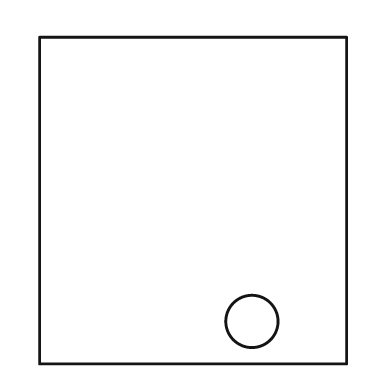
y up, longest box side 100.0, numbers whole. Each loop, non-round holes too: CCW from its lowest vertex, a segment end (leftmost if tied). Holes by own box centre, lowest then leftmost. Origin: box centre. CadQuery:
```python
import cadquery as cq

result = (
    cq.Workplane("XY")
    .moveTo(-47.0, -50.0)
    .lineTo(47.0, -50.0)
    .lineTo(47.0, 50.0)
    .lineTo(-47.0, 50.0)
    .close()
    .moveTo(18.0, -37.0)
    .circle(8.0)
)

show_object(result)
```